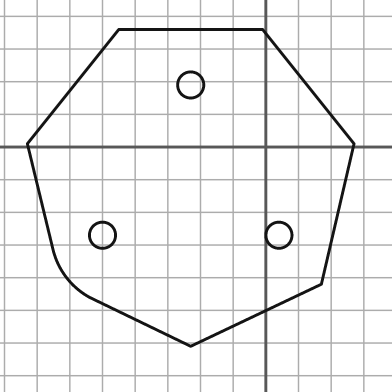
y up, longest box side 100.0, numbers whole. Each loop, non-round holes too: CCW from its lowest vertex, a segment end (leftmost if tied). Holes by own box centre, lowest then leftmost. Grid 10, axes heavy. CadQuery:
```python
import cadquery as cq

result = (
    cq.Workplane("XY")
    .moveTo(-23.0, -61.0)
    .lineTo(17.0, -42.0)
    .lineTo(27.0, 1.0)
    .lineTo(-1.0, 36.0)
    .lineTo(-45.0, 36.0)
    .lineTo(-73.0, 1.0)
    .lineTo(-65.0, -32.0)
    .threePointArc((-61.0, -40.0), (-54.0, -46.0))
    .close()
    .moveTo(-50.0, -27.0)
    .circle(4.0)
    .moveTo(4.0, -27.0)
    .circle(4.0)
    .moveTo(-23.0, 19.0)
    .circle(4.0)
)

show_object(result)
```